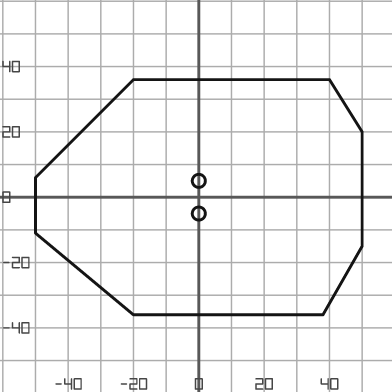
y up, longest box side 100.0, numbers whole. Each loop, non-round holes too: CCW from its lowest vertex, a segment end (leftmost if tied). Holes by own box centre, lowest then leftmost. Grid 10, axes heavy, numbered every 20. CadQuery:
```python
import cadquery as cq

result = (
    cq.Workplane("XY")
    .moveTo(-20.0, -36.0)
    .lineTo(38.0, -36.0)
    .lineTo(50.0, -15.0)
    .lineTo(50.0, 20.0)
    .lineTo(40.0, 36.0)
    .lineTo(-20.0, 36.0)
    .lineTo(-50.0, 6.0)
    .lineTo(-50.0, -11.0)
    .close()
    .moveTo(0.0, -5.0)
    .circle(2.0)
    .moveTo(0.0, 5.0)
    .circle(2.0)
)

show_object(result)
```